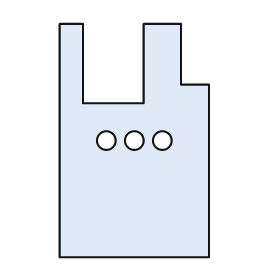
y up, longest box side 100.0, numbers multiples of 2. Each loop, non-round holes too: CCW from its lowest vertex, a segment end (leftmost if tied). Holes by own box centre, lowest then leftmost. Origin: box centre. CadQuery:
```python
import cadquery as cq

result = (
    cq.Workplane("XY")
    .moveTo(-32.0, -50.0)
    .lineTo(32.0, -50.0)
    .lineTo(32.0, 24.0)
    .lineTo(20.0, 24.0)
    .lineTo(20.0, 50.0)
    .lineTo(4.0, 50.0)
    .lineTo(4.0, 16.0)
    .lineTo(-22.0, 16.0)
    .lineTo(-22.0, 50.0)
    .lineTo(-32.0, 50.0)
    .close()
    .moveTo(-12.0, 0.0)
    .circle(4.0)
    .moveTo(0.0, 0.0)
    .circle(4.0)
    .moveTo(12.0, 0.0)
    .circle(4.0)
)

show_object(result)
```